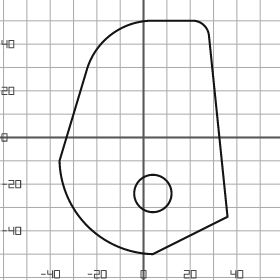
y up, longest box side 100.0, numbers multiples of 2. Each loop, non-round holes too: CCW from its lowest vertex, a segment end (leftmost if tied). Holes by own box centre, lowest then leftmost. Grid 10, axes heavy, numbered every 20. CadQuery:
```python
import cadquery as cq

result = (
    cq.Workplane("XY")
    .moveTo(4.0, -50.0)
    .lineTo(36.0, -34.0)
    .lineTo(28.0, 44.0)
    .threePointArc((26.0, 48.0), (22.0, 50.0))
    .lineTo(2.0, 50.0)
    .threePointArc((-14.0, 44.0), (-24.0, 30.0))
    .lineTo(-36.0, -10.0)
    .threePointArc((-24.0, -38.0), (4.0, -50.0))
    .close()
    .moveTo(4.0, -24.0)
    .circle(8.0)
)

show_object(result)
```